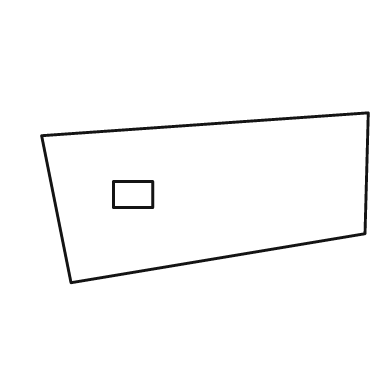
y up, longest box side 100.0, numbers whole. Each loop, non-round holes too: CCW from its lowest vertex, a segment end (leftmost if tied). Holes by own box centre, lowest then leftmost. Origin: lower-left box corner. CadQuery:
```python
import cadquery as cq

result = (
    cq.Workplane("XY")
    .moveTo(9.0, 0.0)
    .lineTo(99.0, 15.0)
    .lineTo(100.0, 52.0)
    .lineTo(0.0, 45.0)
    .close()
    .moveTo(22.0, 23.0)
    .lineTo(34.0, 23.0)
    .lineTo(34.0, 31.0)
    .lineTo(22.0, 31.0)
    .close()
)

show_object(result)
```